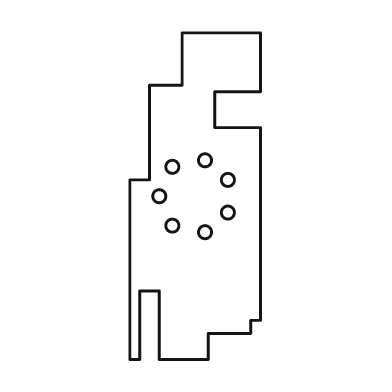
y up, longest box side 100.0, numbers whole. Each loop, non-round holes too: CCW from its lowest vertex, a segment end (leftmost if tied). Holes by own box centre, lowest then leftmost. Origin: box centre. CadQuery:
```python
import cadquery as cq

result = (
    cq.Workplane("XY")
    .moveTo(-20.0, -50.0)
    .lineTo(-17.0, -50.0)
    .lineTo(-17.0, -29.0)
    .lineTo(-11.0, -29.0)
    .lineTo(-11.0, -50.0)
    .lineTo(4.0, -50.0)
    .lineTo(4.0, -42.0)
    .lineTo(17.0, -42.0)
    .lineTo(17.0, -38.0)
    .lineTo(20.0, -38.0)
    .lineTo(20.0, 21.0)
    .lineTo(6.0, 21.0)
    .lineTo(6.0, 32.0)
    .lineTo(20.0, 32.0)
    .lineTo(20.0, 50.0)
    .lineTo(-4.0, 50.0)
    .lineTo(-4.0, 34.0)
    .lineTo(-14.0, 34.0)
    .lineTo(-14.0, 5.0)
    .lineTo(-20.0, 5.0)
    .close()
    .moveTo(3.0, -11.0)
    .circle(2.0)
    .moveTo(-7.0, -9.0)
    .circle(2.0)
    .moveTo(10.0, -5.0)
    .circle(2.0)
    .moveTo(-11.0, 0.0)
    .circle(2.0)
    .moveTo(10.0, 5.0)
    .circle(2.0)
    .moveTo(-7.0, 9.0)
    .circle(2.0)
    .moveTo(3.0, 11.0)
    .circle(2.0)
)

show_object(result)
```